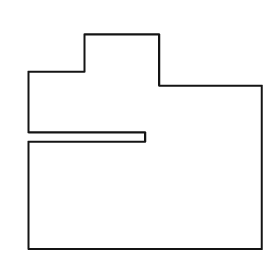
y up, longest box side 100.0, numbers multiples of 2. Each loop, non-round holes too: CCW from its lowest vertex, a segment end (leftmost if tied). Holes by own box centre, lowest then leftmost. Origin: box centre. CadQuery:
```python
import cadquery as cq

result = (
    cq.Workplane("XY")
    .moveTo(-50.0, -46.0)
    .lineTo(50.0, -46.0)
    .lineTo(50.0, 24.0)
    .lineTo(6.0, 24.0)
    .lineTo(6.0, 46.0)
    .lineTo(-26.0, 46.0)
    .lineTo(-26.0, 30.0)
    .lineTo(-50.0, 30.0)
    .lineTo(-50.0, 4.0)
    .lineTo(0.0, 4.0)
    .lineTo(0.0, 0.0)
    .lineTo(-50.0, 0.0)
    .close()
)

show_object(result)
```